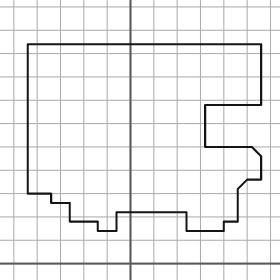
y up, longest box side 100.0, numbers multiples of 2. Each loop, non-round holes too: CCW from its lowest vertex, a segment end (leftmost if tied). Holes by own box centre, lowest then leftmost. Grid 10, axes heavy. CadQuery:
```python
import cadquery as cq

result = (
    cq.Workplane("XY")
    .moveTo(-14.0, 14.0)
    .lineTo(-6.0, 14.0)
    .lineTo(-6.0, 22.0)
    .lineTo(24.0, 22.0)
    .lineTo(24.0, 14.0)
    .lineTo(40.0, 14.0)
    .lineTo(40.0, 18.0)
    .lineTo(46.0, 18.0)
    .lineTo(46.0, 32.0)
    .lineTo(50.0, 36.0)
    .lineTo(56.0, 36.0)
    .lineTo(56.0, 46.0)
    .lineTo(52.0, 50.0)
    .lineTo(32.0, 50.0)
    .lineTo(32.0, 68.0)
    .lineTo(56.0, 68.0)
    .lineTo(56.0, 94.0)
    .lineTo(-44.0, 94.0)
    .lineTo(-44.0, 30.0)
    .lineTo(-34.0, 30.0)
    .lineTo(-34.0, 26.0)
    .lineTo(-26.0, 26.0)
    .lineTo(-26.0, 18.0)
    .lineTo(-14.0, 18.0)
    .close()
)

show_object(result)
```